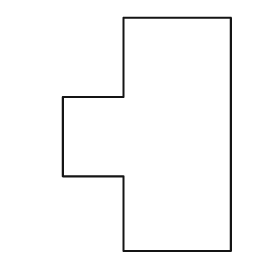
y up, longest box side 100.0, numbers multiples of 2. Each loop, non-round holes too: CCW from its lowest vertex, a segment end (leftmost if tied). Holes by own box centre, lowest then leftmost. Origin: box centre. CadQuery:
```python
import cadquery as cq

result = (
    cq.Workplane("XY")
    .moveTo(-10.0, -50.0)
    .lineTo(36.0, -50.0)
    .lineTo(36.0, 50.0)
    .lineTo(-10.0, 50.0)
    .lineTo(-10.0, 16.0)
    .lineTo(-36.0, 16.0)
    .lineTo(-36.0, -18.0)
    .lineTo(-10.0, -18.0)
    .close()
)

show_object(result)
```